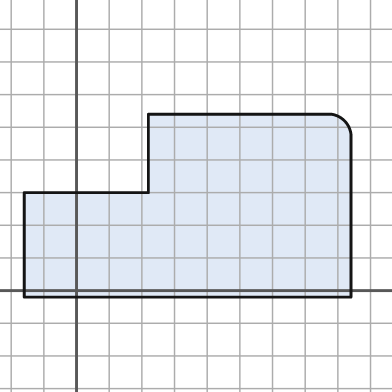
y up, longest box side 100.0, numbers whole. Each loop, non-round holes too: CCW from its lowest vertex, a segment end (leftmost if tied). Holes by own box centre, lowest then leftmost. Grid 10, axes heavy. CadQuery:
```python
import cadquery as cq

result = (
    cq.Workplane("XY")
    .moveTo(-16.0, -2.0)
    .lineTo(84.0, -2.0)
    .lineTo(84.0, 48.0)
    .threePointArc((82.0, 52.0), (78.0, 54.0))
    .lineTo(22.0, 54.0)
    .lineTo(22.0, 30.0)
    .lineTo(-16.0, 30.0)
    .close()
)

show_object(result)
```